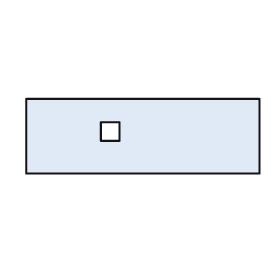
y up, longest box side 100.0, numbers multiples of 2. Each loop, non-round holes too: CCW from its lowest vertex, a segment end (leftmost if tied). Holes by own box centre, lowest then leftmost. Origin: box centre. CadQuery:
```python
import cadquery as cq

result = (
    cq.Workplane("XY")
    .moveTo(-50.0, -16.0)
    .lineTo(50.0, -16.0)
    .lineTo(50.0, 16.0)
    .lineTo(-50.0, 16.0)
    .close()
    .moveTo(-18.0, -2.0)
    .lineTo(-10.0, -2.0)
    .lineTo(-10.0, 6.0)
    .lineTo(-18.0, 6.0)
    .close()
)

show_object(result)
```